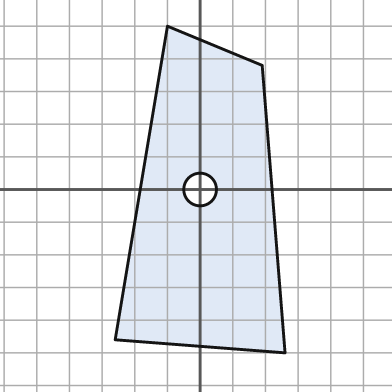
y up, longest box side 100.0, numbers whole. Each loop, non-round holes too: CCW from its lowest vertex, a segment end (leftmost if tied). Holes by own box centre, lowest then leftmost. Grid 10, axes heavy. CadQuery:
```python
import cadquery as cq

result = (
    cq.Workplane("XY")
    .moveTo(26.0, -50.0)
    .lineTo(19.0, 38.0)
    .lineTo(-10.0, 50.0)
    .lineTo(-26.0, -46.0)
    .close()
    .moveTo(0.0, 0.0)
    .circle(5.0)
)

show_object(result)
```